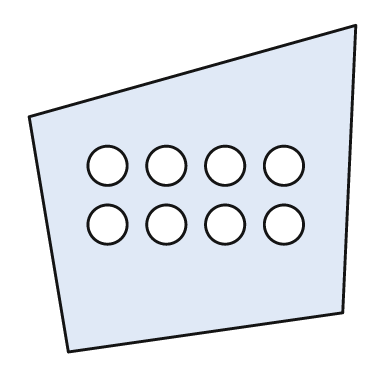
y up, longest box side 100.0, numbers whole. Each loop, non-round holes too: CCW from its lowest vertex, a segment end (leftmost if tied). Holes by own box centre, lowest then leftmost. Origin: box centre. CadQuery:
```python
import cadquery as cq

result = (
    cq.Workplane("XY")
    .moveTo(-38.0, -50.0)
    .lineTo(46.0, -38.0)
    .lineTo(50.0, 50.0)
    .lineTo(-50.0, 22.0)
    .close()
    .moveTo(-26.0, -11.0)
    .circle(6.0)
    .moveTo(-8.0, -11.0)
    .circle(6.0)
    .moveTo(10.0, -11.0)
    .circle(6.0)
    .moveTo(28.0, -11.0)
    .circle(6.0)
    .moveTo(-26.0, 7.0)
    .circle(6.0)
    .moveTo(-8.0, 7.0)
    .circle(6.0)
    .moveTo(10.0, 7.0)
    .circle(6.0)
    .moveTo(28.0, 7.0)
    .circle(6.0)
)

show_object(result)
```